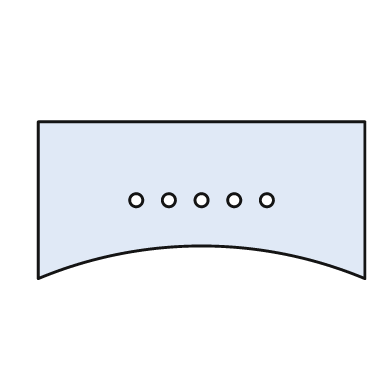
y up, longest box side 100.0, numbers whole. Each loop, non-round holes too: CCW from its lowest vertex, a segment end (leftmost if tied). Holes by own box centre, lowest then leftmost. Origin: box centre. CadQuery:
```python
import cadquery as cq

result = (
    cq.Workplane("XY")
    .moveTo(-50.0, -24.0)
    .threePointArc((0.0, -14.0), (50.0, -24.0))
    .lineTo(50.0, 24.0)
    .lineTo(-50.0, 24.0)
    .close()
    .moveTo(-20.0, 0.0)
    .circle(2.0)
    .moveTo(-10.0, 0.0)
    .circle(2.0)
    .moveTo(0.0, 0.0)
    .circle(2.0)
    .moveTo(10.0, 0.0)
    .circle(2.0)
    .moveTo(20.0, 0.0)
    .circle(2.0)
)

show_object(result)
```